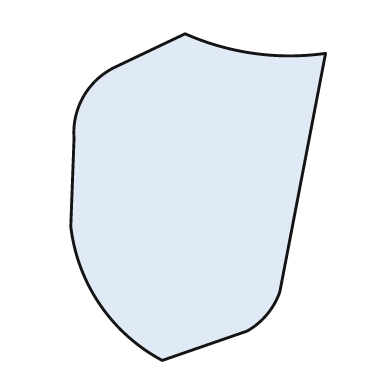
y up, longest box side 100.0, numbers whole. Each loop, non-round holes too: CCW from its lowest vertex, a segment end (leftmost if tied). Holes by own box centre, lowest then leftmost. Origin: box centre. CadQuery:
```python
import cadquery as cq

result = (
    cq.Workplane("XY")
    .moveTo(-11.0, -50.0)
    .lineTo(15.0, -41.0)
    .threePointArc((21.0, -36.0), (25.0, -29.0))
    .lineTo(39.0, 44.0)
    .threePointArc((17.0, 44.0), (-4.0, 50.0))
    .lineTo(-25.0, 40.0)
    .threePointArc((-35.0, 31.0), (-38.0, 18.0))
    .lineTo(-39.0, -9.0)
    .threePointArc((-30.0, -33.0), (-11.0, -50.0))
    .close()
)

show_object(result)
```